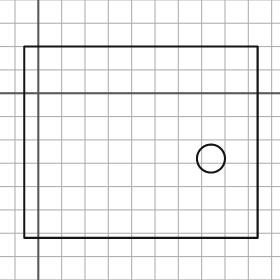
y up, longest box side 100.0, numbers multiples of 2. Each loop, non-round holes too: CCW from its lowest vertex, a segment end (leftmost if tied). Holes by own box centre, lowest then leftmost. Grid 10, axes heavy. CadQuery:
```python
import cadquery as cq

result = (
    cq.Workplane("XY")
    .moveTo(-6.0, -62.0)
    .lineTo(94.0, -62.0)
    .lineTo(94.0, 20.0)
    .lineTo(-6.0, 20.0)
    .close()
    .moveTo(74.0, -28.0)
    .circle(6.0)
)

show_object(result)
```